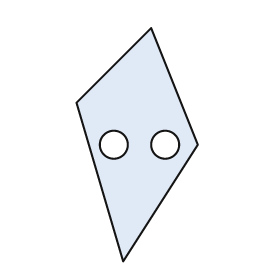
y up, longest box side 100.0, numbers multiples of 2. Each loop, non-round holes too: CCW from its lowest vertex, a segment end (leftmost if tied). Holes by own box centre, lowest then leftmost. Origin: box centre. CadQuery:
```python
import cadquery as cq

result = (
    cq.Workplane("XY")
    .moveTo(-6.0, -50.0)
    .lineTo(26.0, 0.0)
    .lineTo(6.0, 50.0)
    .lineTo(-26.0, 18.0)
    .close()
    .moveTo(-10.0, 0.0)
    .circle(6.0)
    .moveTo(12.0, 0.0)
    .circle(6.0)
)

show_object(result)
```